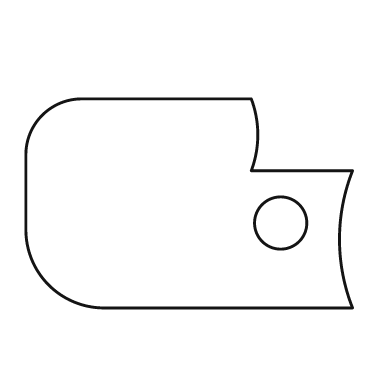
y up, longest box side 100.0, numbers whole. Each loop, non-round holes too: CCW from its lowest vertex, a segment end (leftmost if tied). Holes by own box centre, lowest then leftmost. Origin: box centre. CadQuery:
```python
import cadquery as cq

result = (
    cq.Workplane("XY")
    .moveTo(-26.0, -32.0)
    .lineTo(50.0, -32.0)
    .threePointArc((46.0, -11.0), (50.0, 10.0))
    .lineTo(19.0, 10.0)
    .threePointArc((21.0, 21.0), (19.0, 32.0))
    .lineTo(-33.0, 32.0)
    .threePointArc((-45.0, 27.0), (-50.0, 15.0))
    .lineTo(-50.0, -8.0)
    .threePointArc((-43.0, -25.0), (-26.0, -32.0))
    .close()
    .moveTo(28.0, -6.0)
    .circle(8.0)
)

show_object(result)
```